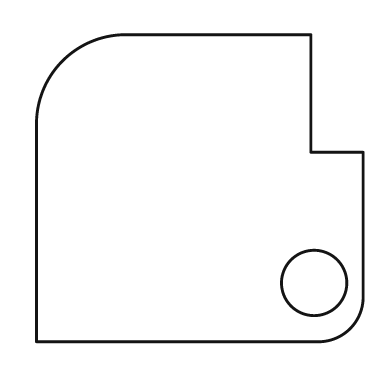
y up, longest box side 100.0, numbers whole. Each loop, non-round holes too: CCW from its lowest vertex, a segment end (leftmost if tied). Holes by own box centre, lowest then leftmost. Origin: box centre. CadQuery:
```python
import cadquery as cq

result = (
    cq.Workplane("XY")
    .moveTo(-50.0, -47.0)
    .lineTo(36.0, -47.0)
    .threePointArc((46.0, -43.0), (50.0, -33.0))
    .lineTo(50.0, 11.0)
    .lineTo(34.0, 11.0)
    .lineTo(34.0, 47.0)
    .lineTo(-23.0, 47.0)
    .threePointArc((-42.0, 39.0), (-50.0, 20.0))
    .close()
    .moveTo(35.0, -29.0)
    .circle(10.0)
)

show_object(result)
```